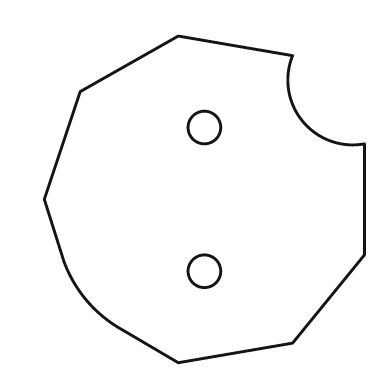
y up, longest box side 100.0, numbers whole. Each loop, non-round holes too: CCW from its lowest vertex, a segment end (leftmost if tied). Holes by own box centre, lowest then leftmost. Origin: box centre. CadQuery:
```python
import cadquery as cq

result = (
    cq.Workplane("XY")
    .moveTo(-8.0, -50.0)
    .lineTo(27.0, -44.0)
    .lineTo(49.0, -17.0)
    .lineTo(49.0, 17.0)
    .threePointArc((30.0, 24.0), (27.0, 44.0))
    .lineTo(-8.0, 50.0)
    .lineTo(-38.0, 33.0)
    .lineTo(-49.0, 0.0)
    .lineTo(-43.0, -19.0)
    .threePointArc((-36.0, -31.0), (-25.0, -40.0))
    .close()
    .moveTo(0.0, -22.0)
    .circle(5.0)
    .moveTo(0.0, 22.0)
    .circle(5.0)
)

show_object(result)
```